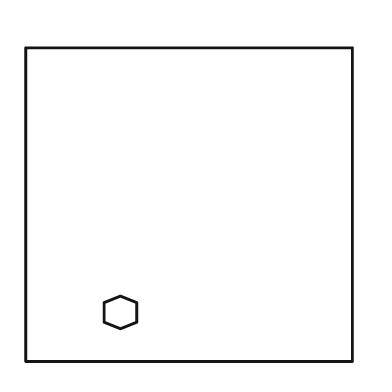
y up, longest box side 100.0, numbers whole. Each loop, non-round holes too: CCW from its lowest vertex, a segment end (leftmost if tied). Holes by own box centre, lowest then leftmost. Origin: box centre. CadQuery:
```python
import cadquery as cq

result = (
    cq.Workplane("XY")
    .moveTo(-50.0, -48.0)
    .lineTo(50.0, -48.0)
    .lineTo(50.0, 48.0)
    .lineTo(-50.0, 48.0)
    .close()
    .moveTo(-21.0, -38.0)
    .lineTo(-16.0, -36.0)
    .lineTo(-16.0, -30.0)
    .lineTo(-21.0, -28.0)
    .lineTo(-26.0, -30.0)
    .lineTo(-26.0, -36.0)
    .close()
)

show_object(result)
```